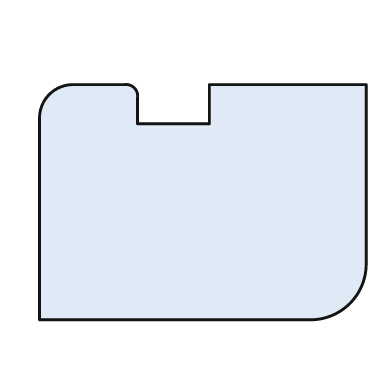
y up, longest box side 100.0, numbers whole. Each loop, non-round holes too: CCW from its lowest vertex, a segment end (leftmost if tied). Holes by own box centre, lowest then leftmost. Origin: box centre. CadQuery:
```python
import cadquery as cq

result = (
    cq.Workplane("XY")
    .moveTo(-50.0, -36.0)
    .lineTo(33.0, -36.0)
    .threePointArc((45.0, -31.0), (50.0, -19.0))
    .lineTo(50.0, 36.0)
    .lineTo(2.0, 36.0)
    .lineTo(2.0, 24.0)
    .lineTo(-20.0, 24.0)
    .lineTo(-20.0, 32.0)
    .threePointArc((-21.0, 35.0), (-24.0, 36.0))
    .lineTo(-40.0, 36.0)
    .threePointArc((-47.0, 33.0), (-50.0, 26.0))
    .close()
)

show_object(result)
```